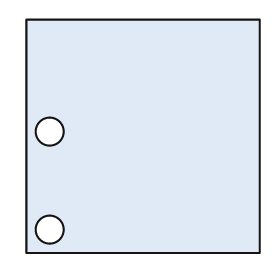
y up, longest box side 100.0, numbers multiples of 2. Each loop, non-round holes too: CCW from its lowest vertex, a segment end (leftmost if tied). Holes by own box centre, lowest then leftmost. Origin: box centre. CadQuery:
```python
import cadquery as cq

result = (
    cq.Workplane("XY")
    .moveTo(-50.0, -50.0)
    .lineTo(50.0, -50.0)
    .lineTo(50.0, 50.0)
    .lineTo(-50.0, 50.0)
    .close()
    .moveTo(-40.0, -40.0)
    .circle(6.0)
    .moveTo(-40.0, 2.0)
    .circle(6.0)
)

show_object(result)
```